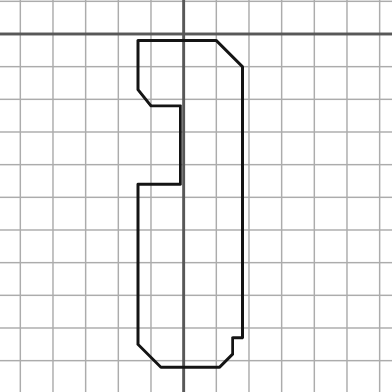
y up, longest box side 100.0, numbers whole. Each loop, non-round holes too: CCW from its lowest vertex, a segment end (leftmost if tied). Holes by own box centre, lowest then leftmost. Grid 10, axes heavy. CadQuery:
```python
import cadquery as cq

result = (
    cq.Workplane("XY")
    .moveTo(-7.0, -102.0)
    .lineTo(11.0, -102.0)
    .lineTo(15.0, -98.0)
    .lineTo(15.0, -93.0)
    .lineTo(18.0, -93.0)
    .lineTo(18.0, -10.0)
    .lineTo(10.0, -2.0)
    .lineTo(-14.0, -2.0)
    .lineTo(-14.0, -17.0)
    .lineTo(-10.0, -22.0)
    .lineTo(-1.0, -22.0)
    .lineTo(-1.0, -46.0)
    .lineTo(-14.0, -46.0)
    .lineTo(-14.0, -95.0)
    .close()
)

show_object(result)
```